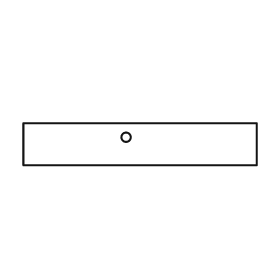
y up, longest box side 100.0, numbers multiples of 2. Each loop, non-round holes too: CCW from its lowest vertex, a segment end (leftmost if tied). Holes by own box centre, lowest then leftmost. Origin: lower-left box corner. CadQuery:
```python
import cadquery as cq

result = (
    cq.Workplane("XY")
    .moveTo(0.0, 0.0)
    .lineTo(100.0, 0.0)
    .lineTo(100.0, 18.0)
    .lineTo(0.0, 18.0)
    .close()
    .moveTo(44.0, 12.0)
    .circle(2.0)
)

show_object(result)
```